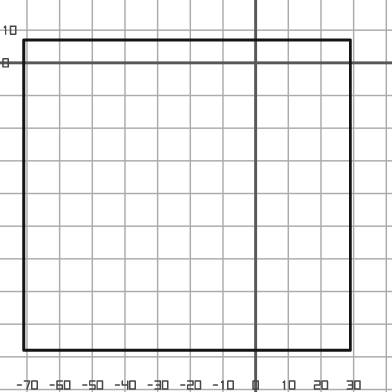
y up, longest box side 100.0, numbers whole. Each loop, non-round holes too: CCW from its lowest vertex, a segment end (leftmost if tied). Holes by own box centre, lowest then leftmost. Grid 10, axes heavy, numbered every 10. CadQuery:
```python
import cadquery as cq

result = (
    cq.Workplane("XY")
    .moveTo(-71.0, -88.0)
    .lineTo(29.0, -88.0)
    .lineTo(29.0, 7.0)
    .lineTo(-71.0, 7.0)
    .close()
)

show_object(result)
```